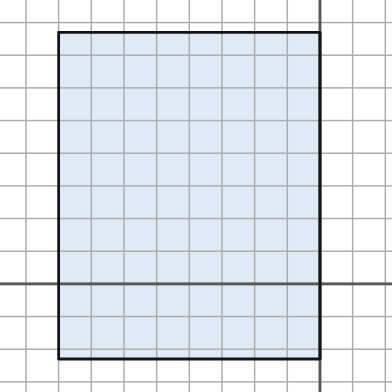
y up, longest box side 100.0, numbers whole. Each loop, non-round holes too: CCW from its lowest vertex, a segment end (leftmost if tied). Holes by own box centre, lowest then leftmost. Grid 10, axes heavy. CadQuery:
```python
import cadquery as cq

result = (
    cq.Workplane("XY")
    .moveTo(-80.0, -23.0)
    .lineTo(0.0, -23.0)
    .lineTo(0.0, 77.0)
    .lineTo(-80.0, 77.0)
    .close()
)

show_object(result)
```